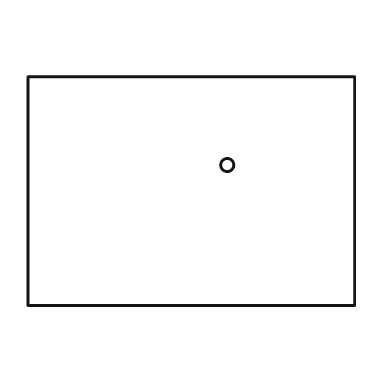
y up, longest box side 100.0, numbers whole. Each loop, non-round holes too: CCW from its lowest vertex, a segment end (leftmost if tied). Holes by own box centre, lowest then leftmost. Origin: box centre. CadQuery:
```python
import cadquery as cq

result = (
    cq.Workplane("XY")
    .moveTo(-50.0, -35.0)
    .lineTo(50.0, -35.0)
    .lineTo(50.0, 35.0)
    .lineTo(-50.0, 35.0)
    .close()
    .moveTo(11.0, 8.0)
    .circle(2.0)
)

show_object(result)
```